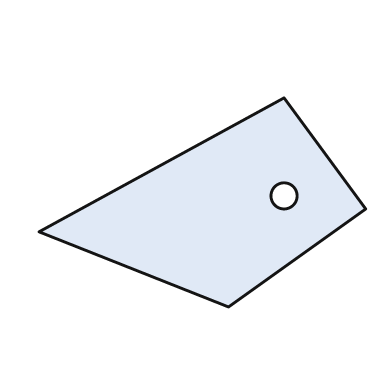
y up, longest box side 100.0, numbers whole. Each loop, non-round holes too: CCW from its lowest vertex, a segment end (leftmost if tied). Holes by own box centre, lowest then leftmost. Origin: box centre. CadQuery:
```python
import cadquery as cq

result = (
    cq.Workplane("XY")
    .moveTo(8.0, -32.0)
    .lineTo(50.0, -2.0)
    .lineTo(25.0, 32.0)
    .lineTo(-50.0, -9.0)
    .close()
    .moveTo(25.0, 2.0)
    .circle(4.0)
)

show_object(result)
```